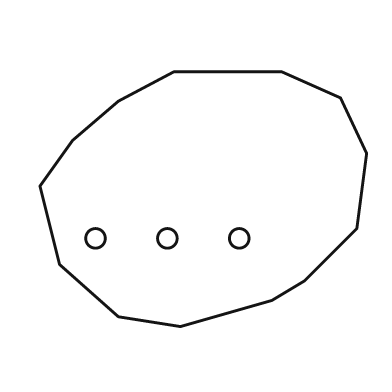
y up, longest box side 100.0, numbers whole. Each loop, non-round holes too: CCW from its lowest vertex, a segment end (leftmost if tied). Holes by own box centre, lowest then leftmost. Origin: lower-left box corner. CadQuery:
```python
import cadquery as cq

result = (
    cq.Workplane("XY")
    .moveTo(43.0, 0.0)
    .lineTo(71.0, 8.0)
    .lineTo(81.0, 14.0)
    .lineTo(97.0, 30.0)
    .lineTo(100.0, 53.0)
    .lineTo(92.0, 70.0)
    .lineTo(74.0, 78.0)
    .lineTo(41.0, 78.0)
    .lineTo(24.0, 69.0)
    .lineTo(10.0, 57.0)
    .lineTo(0.0, 43.0)
    .lineTo(6.0, 19.0)
    .lineTo(24.0, 3.0)
    .close()
    .moveTo(17.0, 27.0)
    .circle(3.0)
    .moveTo(39.0, 27.0)
    .circle(3.0)
    .moveTo(61.0, 27.0)
    .circle(3.0)
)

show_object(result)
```